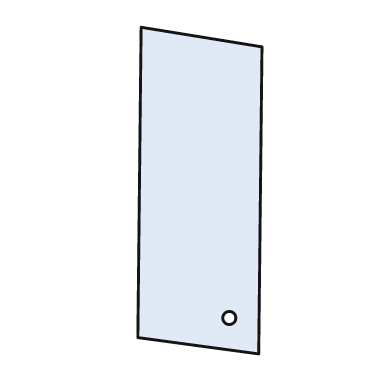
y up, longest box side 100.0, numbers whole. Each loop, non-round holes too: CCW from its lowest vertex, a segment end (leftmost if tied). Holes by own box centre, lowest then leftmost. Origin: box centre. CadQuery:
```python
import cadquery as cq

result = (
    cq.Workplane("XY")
    .moveTo(18.0, -50.0)
    .lineTo(19.0, 44.0)
    .lineTo(-18.0, 50.0)
    .lineTo(-19.0, -45.0)
    .close()
    .moveTo(9.0, -39.0)
    .circle(2.0)
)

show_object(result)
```